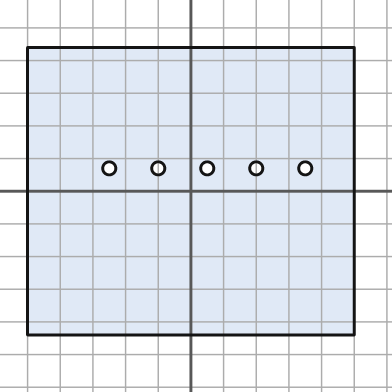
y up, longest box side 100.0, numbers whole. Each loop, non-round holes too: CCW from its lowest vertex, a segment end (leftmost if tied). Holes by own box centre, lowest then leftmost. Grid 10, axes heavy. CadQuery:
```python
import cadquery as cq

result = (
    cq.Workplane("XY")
    .moveTo(-50.0, -44.0)
    .lineTo(50.0, -44.0)
    .lineTo(50.0, 44.0)
    .lineTo(-50.0, 44.0)
    .close()
    .moveTo(-25.0, 7.0)
    .circle(2.0)
    .moveTo(-10.0, 7.0)
    .circle(2.0)
    .moveTo(5.0, 7.0)
    .circle(2.0)
    .moveTo(20.0, 7.0)
    .circle(2.0)
    .moveTo(35.0, 7.0)
    .circle(2.0)
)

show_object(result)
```